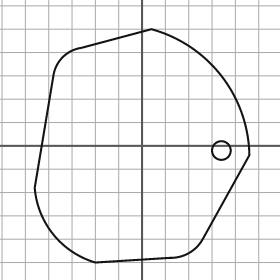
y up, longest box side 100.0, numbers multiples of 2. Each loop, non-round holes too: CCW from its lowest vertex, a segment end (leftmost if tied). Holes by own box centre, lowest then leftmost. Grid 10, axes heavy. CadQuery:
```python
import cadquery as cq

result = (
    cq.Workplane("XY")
    .moveTo(-20.0, -50.0)
    .lineTo(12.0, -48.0)
    .threePointArc((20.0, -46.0), (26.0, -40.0))
    .lineTo(46.0, -4.0)
    .threePointArc((34.0, 30.0), (4.0, 50.0))
    .lineTo(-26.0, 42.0)
    .threePointArc((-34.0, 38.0), (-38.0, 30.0))
    .lineTo(-46.0, -18.0)
    .threePointArc((-38.0, -38.0), (-20.0, -50.0))
    .close()
    .moveTo(34.0, -2.0)
    .circle(4.0)
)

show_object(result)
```